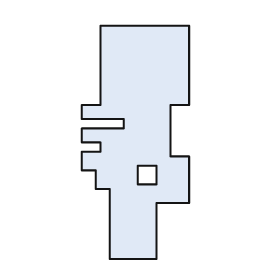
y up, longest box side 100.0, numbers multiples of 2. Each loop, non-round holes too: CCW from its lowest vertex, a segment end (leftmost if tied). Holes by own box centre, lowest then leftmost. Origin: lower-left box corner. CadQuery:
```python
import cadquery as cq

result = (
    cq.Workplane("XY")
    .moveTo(12.0, 0.0)
    .lineTo(32.0, 0.0)
    .lineTo(32.0, 24.0)
    .lineTo(46.0, 24.0)
    .lineTo(46.0, 44.0)
    .lineTo(38.0, 44.0)
    .lineTo(38.0, 66.0)
    .lineTo(46.0, 66.0)
    .lineTo(46.0, 100.0)
    .lineTo(8.0, 100.0)
    .lineTo(8.0, 66.0)
    .lineTo(0.0, 66.0)
    .lineTo(0.0, 60.0)
    .lineTo(18.0, 60.0)
    .lineTo(18.0, 56.0)
    .lineTo(0.0, 56.0)
    .lineTo(0.0, 50.0)
    .lineTo(8.0, 50.0)
    .lineTo(8.0, 46.0)
    .lineTo(0.0, 46.0)
    .lineTo(0.0, 38.0)
    .lineTo(6.0, 38.0)
    .lineTo(6.0, 30.0)
    .lineTo(12.0, 30.0)
    .close()
    .moveTo(24.0, 32.0)
    .lineTo(32.0, 32.0)
    .lineTo(32.0, 40.0)
    .lineTo(24.0, 40.0)
    .close()
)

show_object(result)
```